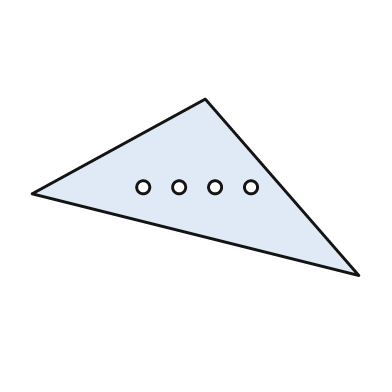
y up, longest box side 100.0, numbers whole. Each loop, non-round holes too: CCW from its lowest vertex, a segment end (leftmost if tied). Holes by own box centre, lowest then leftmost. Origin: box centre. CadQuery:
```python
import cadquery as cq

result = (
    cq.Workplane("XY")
    .moveTo(50.0, -27.0)
    .lineTo(3.0, 27.0)
    .lineTo(-50.0, -2.0)
    .close()
    .moveTo(-16.0, 0.0)
    .circle(2.0)
    .moveTo(-5.0, 0.0)
    .circle(2.0)
    .moveTo(6.0, 0.0)
    .circle(2.0)
    .moveTo(17.0, 0.0)
    .circle(2.0)
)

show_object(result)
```